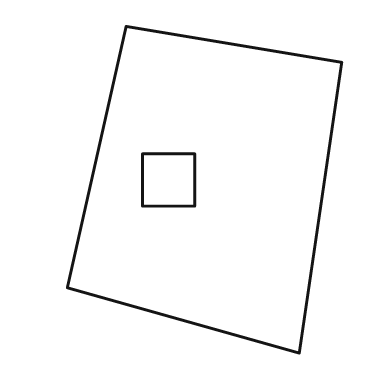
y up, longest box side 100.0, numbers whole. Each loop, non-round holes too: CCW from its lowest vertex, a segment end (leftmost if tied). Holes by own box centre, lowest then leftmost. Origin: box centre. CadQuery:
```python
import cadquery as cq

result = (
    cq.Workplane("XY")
    .moveTo(29.0, -50.0)
    .lineTo(42.0, 39.0)
    .lineTo(-24.0, 50.0)
    .lineTo(-42.0, -30.0)
    .close()
    .moveTo(-19.0, -5.0)
    .lineTo(-3.0, -5.0)
    .lineTo(-3.0, 11.0)
    .lineTo(-19.0, 11.0)
    .close()
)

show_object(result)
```